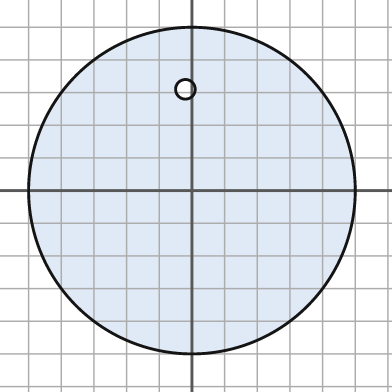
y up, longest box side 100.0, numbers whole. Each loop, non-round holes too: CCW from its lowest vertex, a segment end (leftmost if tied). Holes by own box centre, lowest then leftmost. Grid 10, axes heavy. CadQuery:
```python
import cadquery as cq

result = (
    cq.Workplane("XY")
    .moveTo(0.0, 0.0)
    .circle(50.0)
    .moveTo(-2.0, 31.0)
    .circle(3.0)
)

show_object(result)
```